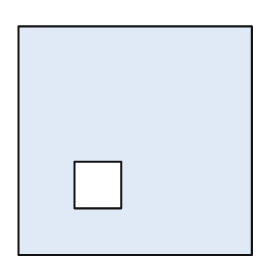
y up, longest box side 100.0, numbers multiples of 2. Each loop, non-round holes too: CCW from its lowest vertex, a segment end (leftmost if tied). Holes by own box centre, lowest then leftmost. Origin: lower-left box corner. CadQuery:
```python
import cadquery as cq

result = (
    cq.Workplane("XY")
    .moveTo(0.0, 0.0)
    .lineTo(100.0, 0.0)
    .lineTo(100.0, 98.0)
    .lineTo(0.0, 98.0)
    .close()
    .moveTo(24.0, 20.0)
    .lineTo(44.0, 20.0)
    .lineTo(44.0, 40.0)
    .lineTo(24.0, 40.0)
    .close()
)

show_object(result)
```